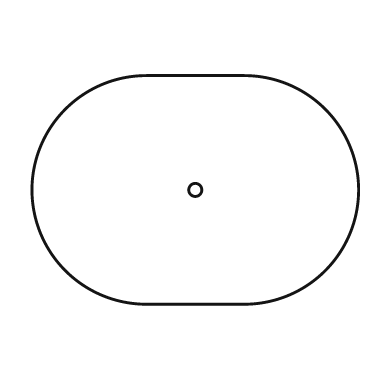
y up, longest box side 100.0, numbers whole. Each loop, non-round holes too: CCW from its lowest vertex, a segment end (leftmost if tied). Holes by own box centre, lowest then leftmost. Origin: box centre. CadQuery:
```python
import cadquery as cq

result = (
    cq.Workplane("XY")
    .moveTo(-15.0, -35.0)
    .lineTo(15.0, -35.0)
    .threePointArc((50.0, 0.0), (15.0, 35.0))
    .lineTo(-15.0, 35.0)
    .threePointArc((-50.0, 0.0), (-15.0, -35.0))
    .close()
    .moveTo(0.0, 0.0)
    .circle(2.0)
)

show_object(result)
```